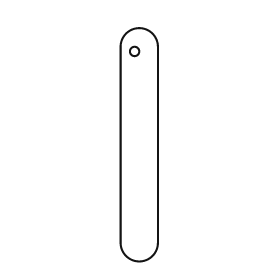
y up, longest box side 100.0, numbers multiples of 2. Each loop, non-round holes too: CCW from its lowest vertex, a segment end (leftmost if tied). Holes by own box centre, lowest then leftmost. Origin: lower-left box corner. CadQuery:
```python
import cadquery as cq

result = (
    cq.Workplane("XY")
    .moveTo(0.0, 8.0)
    .threePointArc((8.0, 0.0), (16.0, 8.0))
    .lineTo(16.0, 92.0)
    .threePointArc((8.0, 100.0), (0.0, 92.0))
    .close()
    .moveTo(6.0, 90.0)
    .circle(2.0)
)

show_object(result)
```